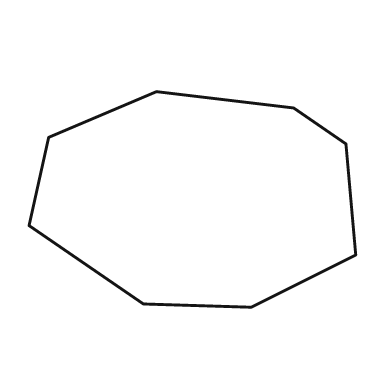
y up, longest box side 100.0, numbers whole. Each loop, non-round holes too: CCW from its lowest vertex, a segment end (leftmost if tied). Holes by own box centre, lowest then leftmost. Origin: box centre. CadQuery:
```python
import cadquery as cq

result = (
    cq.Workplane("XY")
    .moveTo(18.0, -33.0)
    .lineTo(50.0, -17.0)
    .lineTo(47.0, 17.0)
    .lineTo(31.0, 28.0)
    .lineTo(-11.0, 33.0)
    .lineTo(-44.0, 19.0)
    .lineTo(-50.0, -8.0)
    .lineTo(-15.0, -32.0)
    .close()
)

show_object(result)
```